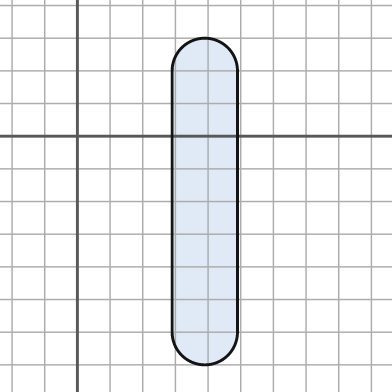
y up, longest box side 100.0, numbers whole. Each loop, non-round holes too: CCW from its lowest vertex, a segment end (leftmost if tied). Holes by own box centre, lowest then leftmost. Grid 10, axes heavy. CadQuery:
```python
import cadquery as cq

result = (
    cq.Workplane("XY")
    .moveTo(29.0, -60.0)
    .threePointArc((39.0, -70.0), (49.0, -60.0))
    .lineTo(49.0, 20.0)
    .threePointArc((39.0, 30.0), (29.0, 20.0))
    .close()
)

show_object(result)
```